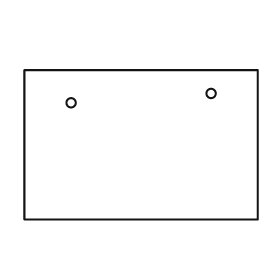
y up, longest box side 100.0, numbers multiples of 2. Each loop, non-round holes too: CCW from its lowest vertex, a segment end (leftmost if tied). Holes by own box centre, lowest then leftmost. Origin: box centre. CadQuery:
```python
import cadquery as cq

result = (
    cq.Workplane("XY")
    .moveTo(-50.0, -32.0)
    .lineTo(50.0, -32.0)
    .lineTo(50.0, 32.0)
    .lineTo(-50.0, 32.0)
    .close()
    .moveTo(-30.0, 18.0)
    .circle(2.0)
    .moveTo(30.0, 22.0)
    .circle(2.0)
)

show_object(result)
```